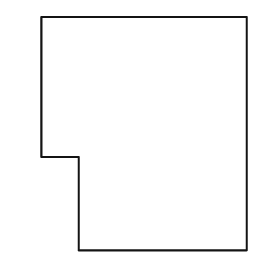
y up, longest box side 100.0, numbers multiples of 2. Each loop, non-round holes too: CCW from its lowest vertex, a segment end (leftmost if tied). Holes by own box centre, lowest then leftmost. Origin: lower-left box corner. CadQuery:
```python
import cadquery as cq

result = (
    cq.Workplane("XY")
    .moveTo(16.0, 0.0)
    .lineTo(88.0, 0.0)
    .lineTo(88.0, 100.0)
    .lineTo(0.0, 100.0)
    .lineTo(0.0, 40.0)
    .lineTo(16.0, 40.0)
    .close()
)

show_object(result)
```